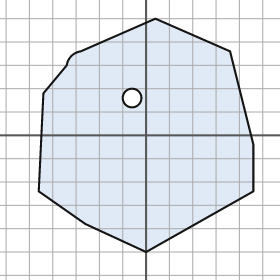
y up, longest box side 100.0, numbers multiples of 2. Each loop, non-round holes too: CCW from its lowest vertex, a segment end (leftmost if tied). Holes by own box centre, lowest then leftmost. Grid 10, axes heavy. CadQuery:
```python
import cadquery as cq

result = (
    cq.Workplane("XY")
    .moveTo(0.0, -50.0)
    .lineTo(46.0, -24.0)
    .lineTo(46.0, -4.0)
    .lineTo(36.0, 36.0)
    .lineTo(4.0, 50.0)
    .lineTo(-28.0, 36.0)
    .threePointArc((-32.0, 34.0), (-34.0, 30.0))
    .lineTo(-44.0, 18.0)
    .lineTo(-46.0, -24.0)
    .lineTo(-26.0, -38.0)
    .close()
    .moveTo(-6.0, 16.0)
    .circle(4.0)
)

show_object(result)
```